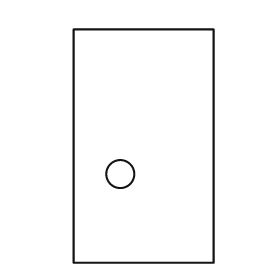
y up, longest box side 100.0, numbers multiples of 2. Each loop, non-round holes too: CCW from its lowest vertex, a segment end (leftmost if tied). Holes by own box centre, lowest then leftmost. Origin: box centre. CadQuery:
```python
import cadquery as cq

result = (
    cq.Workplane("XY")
    .moveTo(-30.0, -50.0)
    .lineTo(30.0, -50.0)
    .lineTo(30.0, 50.0)
    .lineTo(-30.0, 50.0)
    .close()
    .moveTo(-10.0, -12.0)
    .circle(6.0)
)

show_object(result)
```